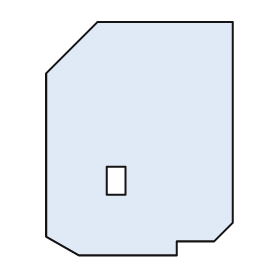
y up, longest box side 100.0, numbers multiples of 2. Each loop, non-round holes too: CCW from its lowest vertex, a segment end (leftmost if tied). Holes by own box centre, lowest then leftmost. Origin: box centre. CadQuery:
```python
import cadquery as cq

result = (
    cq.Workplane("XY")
    .moveTo(-26.0, -50.0)
    .lineTo(16.0, -50.0)
    .lineTo(16.0, -44.0)
    .lineTo(32.0, -44.0)
    .lineTo(40.0, -36.0)
    .lineTo(40.0, 50.0)
    .lineTo(-18.0, 50.0)
    .lineTo(-40.0, 28.0)
    .lineTo(-40.0, -42.0)
    .close()
    .moveTo(-14.0, -24.0)
    .lineTo(-6.0, -24.0)
    .lineTo(-6.0, -12.0)
    .lineTo(-14.0, -12.0)
    .close()
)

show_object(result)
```